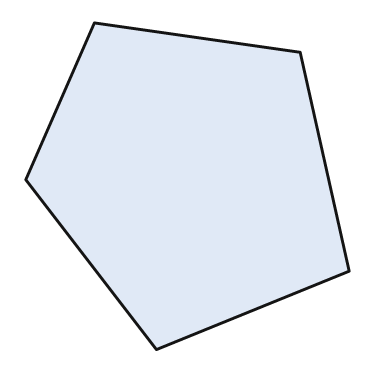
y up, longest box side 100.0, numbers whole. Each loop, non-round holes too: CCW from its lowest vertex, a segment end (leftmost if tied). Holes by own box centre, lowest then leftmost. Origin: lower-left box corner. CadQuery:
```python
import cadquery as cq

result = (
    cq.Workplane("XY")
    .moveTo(40.0, 0.0)
    .lineTo(99.0, 24.0)
    .lineTo(84.0, 91.0)
    .lineTo(21.0, 100.0)
    .lineTo(0.0, 52.0)
    .close()
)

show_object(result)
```